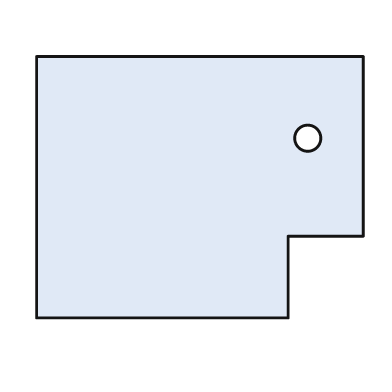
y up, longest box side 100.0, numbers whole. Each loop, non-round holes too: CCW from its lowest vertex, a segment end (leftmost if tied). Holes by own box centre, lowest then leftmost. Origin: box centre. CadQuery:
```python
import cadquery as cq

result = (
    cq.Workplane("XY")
    .moveTo(-50.0, -40.0)
    .lineTo(27.0, -40.0)
    .lineTo(27.0, -15.0)
    .lineTo(50.0, -15.0)
    .lineTo(50.0, 40.0)
    .lineTo(-50.0, 40.0)
    .close()
    .moveTo(33.0, 15.0)
    .circle(4.0)
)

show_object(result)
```